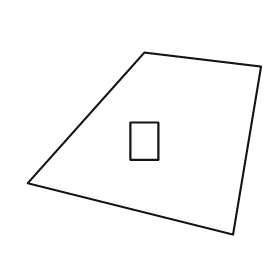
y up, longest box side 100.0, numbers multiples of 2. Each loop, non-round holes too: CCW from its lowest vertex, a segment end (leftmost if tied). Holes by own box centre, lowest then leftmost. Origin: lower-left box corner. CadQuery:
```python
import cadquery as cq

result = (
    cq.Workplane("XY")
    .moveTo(88.0, 0.0)
    .lineTo(100.0, 72.0)
    .lineTo(50.0, 78.0)
    .lineTo(0.0, 22.0)
    .close()
    .moveTo(44.0, 32.0)
    .lineTo(56.0, 32.0)
    .lineTo(56.0, 48.0)
    .lineTo(44.0, 48.0)
    .close()
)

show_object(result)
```